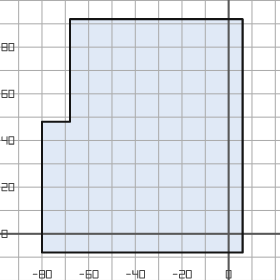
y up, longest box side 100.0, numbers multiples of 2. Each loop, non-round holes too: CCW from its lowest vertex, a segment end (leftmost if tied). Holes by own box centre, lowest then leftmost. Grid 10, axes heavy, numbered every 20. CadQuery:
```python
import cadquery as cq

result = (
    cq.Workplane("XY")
    .moveTo(-80.0, -8.0)
    .lineTo(6.0, -8.0)
    .lineTo(6.0, 92.0)
    .lineTo(-68.0, 92.0)
    .lineTo(-68.0, 48.0)
    .lineTo(-80.0, 48.0)
    .close()
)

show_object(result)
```